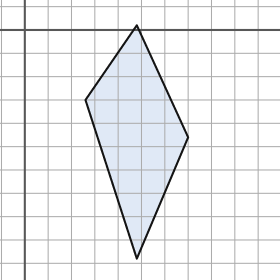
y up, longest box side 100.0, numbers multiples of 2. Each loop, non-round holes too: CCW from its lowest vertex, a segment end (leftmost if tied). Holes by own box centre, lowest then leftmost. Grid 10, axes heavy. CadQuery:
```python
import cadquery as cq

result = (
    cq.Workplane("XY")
    .moveTo(48.0, -98.0)
    .lineTo(70.0, -46.0)
    .lineTo(48.0, 2.0)
    .lineTo(26.0, -30.0)
    .close()
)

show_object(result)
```